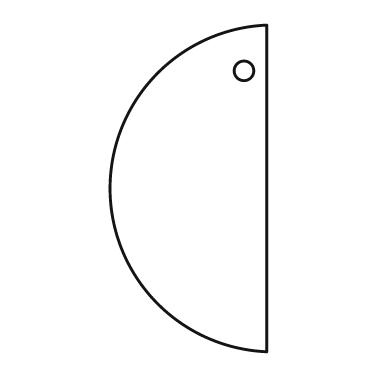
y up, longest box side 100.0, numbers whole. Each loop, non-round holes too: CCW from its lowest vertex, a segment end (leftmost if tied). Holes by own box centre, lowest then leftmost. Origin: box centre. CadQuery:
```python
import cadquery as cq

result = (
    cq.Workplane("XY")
    .moveTo(24.0, -50.0)
    .lineTo(24.0, 50.0)
    .threePointArc((-24.0, 0.0), (24.0, -50.0))
    .close()
    .moveTo(17.0, 36.0)
    .circle(3.0)
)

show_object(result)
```